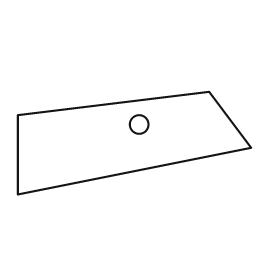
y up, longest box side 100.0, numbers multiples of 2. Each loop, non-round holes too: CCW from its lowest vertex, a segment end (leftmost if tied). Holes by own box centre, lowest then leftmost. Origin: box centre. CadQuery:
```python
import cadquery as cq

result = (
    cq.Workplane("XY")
    .moveTo(-50.0, -22.0)
    .lineTo(50.0, -2.0)
    .lineTo(32.0, 22.0)
    .lineTo(-50.0, 12.0)
    .close()
    .moveTo(2.0, 8.0)
    .circle(4.0)
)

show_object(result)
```